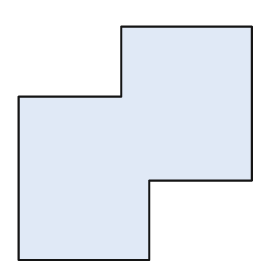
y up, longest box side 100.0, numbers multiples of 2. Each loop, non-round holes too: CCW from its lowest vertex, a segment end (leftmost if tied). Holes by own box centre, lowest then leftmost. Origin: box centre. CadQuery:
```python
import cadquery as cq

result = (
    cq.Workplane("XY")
    .moveTo(-50.0, -50.0)
    .lineTo(6.0, -50.0)
    .lineTo(6.0, -16.0)
    .lineTo(50.0, -16.0)
    .lineTo(50.0, 50.0)
    .lineTo(-6.0, 50.0)
    .lineTo(-6.0, 20.0)
    .lineTo(-50.0, 20.0)
    .close()
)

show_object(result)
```